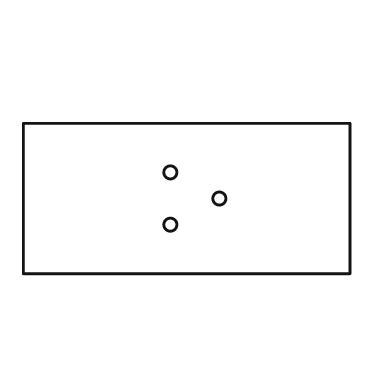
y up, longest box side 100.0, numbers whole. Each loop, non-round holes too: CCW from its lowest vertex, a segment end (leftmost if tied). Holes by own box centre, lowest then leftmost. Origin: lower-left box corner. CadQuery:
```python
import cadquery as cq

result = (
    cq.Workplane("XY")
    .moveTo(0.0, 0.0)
    .lineTo(100.0, 0.0)
    .lineTo(100.0, 46.0)
    .lineTo(0.0, 46.0)
    .close()
    .moveTo(45.0, 15.0)
    .circle(2.0)
    .moveTo(60.0, 23.0)
    .circle(2.0)
    .moveTo(45.0, 31.0)
    .circle(2.0)
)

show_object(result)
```